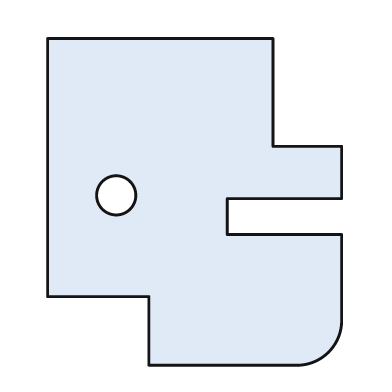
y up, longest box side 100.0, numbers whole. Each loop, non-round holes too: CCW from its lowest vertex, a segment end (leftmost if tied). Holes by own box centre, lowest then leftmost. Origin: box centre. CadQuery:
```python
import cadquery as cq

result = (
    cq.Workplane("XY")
    .moveTo(-14.0, -50.0)
    .lineTo(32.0, -50.0)
    .threePointArc((41.0, -46.0), (45.0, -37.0))
    .lineTo(45.0, -10.0)
    .lineTo(10.0, -10.0)
    .lineTo(10.0, 1.0)
    .lineTo(45.0, 1.0)
    .lineTo(45.0, 17.0)
    .lineTo(24.0, 17.0)
    .lineTo(24.0, 50.0)
    .lineTo(-45.0, 50.0)
    .lineTo(-45.0, -29.0)
    .lineTo(-14.0, -29.0)
    .close()
    .moveTo(-24.0, 2.0)
    .circle(6.0)
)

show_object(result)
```